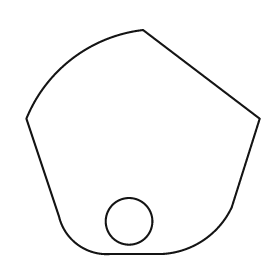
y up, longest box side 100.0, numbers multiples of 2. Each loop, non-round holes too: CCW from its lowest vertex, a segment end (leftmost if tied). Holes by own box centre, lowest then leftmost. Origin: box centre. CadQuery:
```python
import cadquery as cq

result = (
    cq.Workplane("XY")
    .moveTo(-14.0, -48.0)
    .lineTo(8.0, -48.0)
    .threePointArc((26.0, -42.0), (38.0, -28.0))
    .lineTo(50.0, 10.0)
    .lineTo(0.0, 48.0)
    .threePointArc((-30.0, 36.0), (-50.0, 10.0))
    .lineTo(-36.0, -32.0)
    .threePointArc((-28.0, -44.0), (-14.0, -48.0))
    .close()
    .moveTo(-6.0, -34.0)
    .circle(10.0)
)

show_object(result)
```